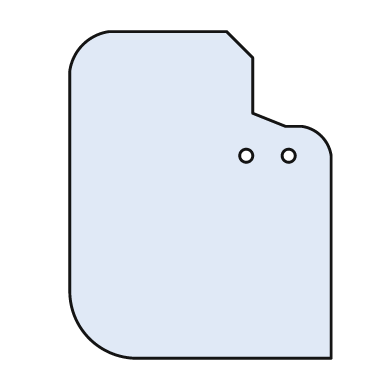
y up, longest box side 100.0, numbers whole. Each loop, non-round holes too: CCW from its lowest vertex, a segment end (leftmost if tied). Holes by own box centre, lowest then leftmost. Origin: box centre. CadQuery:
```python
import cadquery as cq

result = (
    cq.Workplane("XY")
    .moveTo(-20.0, -50.0)
    .lineTo(40.0, -50.0)
    .lineTo(40.0, 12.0)
    .threePointArc((37.0, 18.0), (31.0, 21.0))
    .lineTo(26.0, 21.0)
    .lineTo(16.0, 25.0)
    .lineTo(16.0, 42.0)
    .lineTo(8.0, 50.0)
    .lineTo(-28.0, 50.0)
    .threePointArc((-36.0, 46.0), (-40.0, 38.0))
    .lineTo(-40.0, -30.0)
    .threePointArc((-34.0, -44.0), (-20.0, -50.0))
    .close()
    .moveTo(14.0, 12.0)
    .circle(2.0)
    .moveTo(27.0, 12.0)
    .circle(2.0)
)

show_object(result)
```